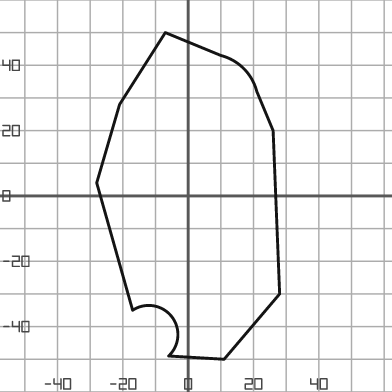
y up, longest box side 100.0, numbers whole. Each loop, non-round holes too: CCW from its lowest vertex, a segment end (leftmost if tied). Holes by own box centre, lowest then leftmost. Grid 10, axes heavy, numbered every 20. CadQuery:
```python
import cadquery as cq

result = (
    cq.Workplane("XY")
    .moveTo(11.0, -50.0)
    .lineTo(28.0, -30.0)
    .lineTo(26.0, 20.0)
    .lineTo(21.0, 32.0)
    .threePointArc((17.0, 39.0), (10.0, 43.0))
    .lineTo(-7.0, 50.0)
    .lineTo(-21.0, 28.0)
    .lineTo(-28.0, 4.0)
    .lineTo(-17.0, -35.0)
    .threePointArc((-5.0, -37.0), (-6.0, -49.0))
    .close()
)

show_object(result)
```